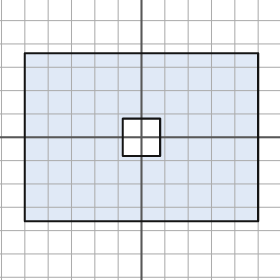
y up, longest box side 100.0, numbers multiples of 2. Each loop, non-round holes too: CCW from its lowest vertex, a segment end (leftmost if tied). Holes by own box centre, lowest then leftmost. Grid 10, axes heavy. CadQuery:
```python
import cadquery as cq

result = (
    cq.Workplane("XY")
    .moveTo(-50.0, -36.0)
    .lineTo(50.0, -36.0)
    .lineTo(50.0, 36.0)
    .lineTo(-50.0, 36.0)
    .close()
    .moveTo(-8.0, -8.0)
    .lineTo(8.0, -8.0)
    .lineTo(8.0, 8.0)
    .lineTo(-8.0, 8.0)
    .close()
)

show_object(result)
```